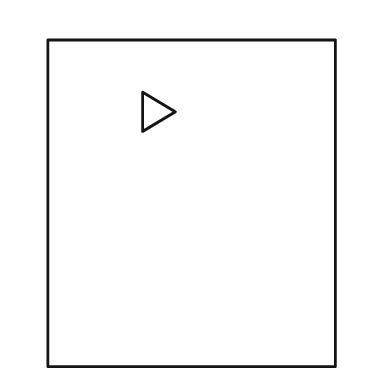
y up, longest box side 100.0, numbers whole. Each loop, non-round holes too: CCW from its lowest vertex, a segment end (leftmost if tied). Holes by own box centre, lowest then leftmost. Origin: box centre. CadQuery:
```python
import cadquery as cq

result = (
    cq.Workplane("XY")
    .moveTo(-44.0, -50.0)
    .lineTo(44.0, -50.0)
    .lineTo(44.0, 50.0)
    .lineTo(-44.0, 50.0)
    .close()
    .moveTo(-15.0, 22.0)
    .lineTo(-5.0, 28.0)
    .lineTo(-15.0, 34.0)
    .close()
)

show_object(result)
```